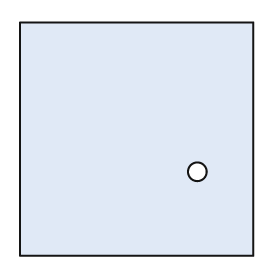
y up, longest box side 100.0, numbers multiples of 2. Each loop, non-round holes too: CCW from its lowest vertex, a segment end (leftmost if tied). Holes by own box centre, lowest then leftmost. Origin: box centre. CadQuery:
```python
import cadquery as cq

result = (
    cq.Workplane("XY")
    .moveTo(-50.0, -50.0)
    .lineTo(50.0, -50.0)
    .lineTo(50.0, 50.0)
    .lineTo(-50.0, 50.0)
    .close()
    .moveTo(26.0, -14.0)
    .circle(4.0)
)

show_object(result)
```